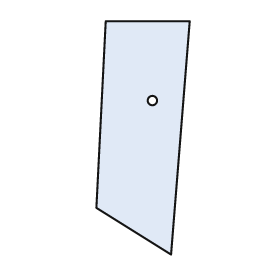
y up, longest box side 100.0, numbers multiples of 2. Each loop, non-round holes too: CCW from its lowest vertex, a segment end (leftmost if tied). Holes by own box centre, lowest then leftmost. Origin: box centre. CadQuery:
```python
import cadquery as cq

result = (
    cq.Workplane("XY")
    .moveTo(12.0, -50.0)
    .lineTo(20.0, 50.0)
    .lineTo(-16.0, 50.0)
    .lineTo(-20.0, -30.0)
    .close()
    .moveTo(4.0, 16.0)
    .circle(2.0)
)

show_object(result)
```